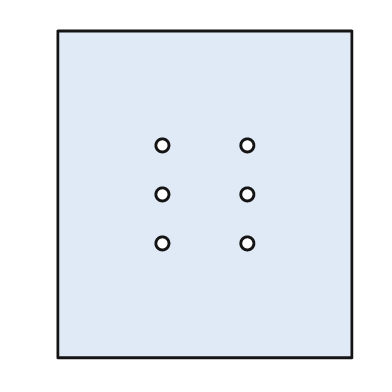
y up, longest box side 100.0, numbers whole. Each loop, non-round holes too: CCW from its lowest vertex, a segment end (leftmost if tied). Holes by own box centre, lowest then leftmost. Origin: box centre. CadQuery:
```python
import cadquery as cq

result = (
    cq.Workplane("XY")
    .moveTo(-45.0, -50.0)
    .lineTo(45.0, -50.0)
    .lineTo(45.0, 50.0)
    .lineTo(-45.0, 50.0)
    .close()
    .moveTo(-13.0, -15.0)
    .circle(2.0)
    .moveTo(13.0, -15.0)
    .circle(2.0)
    .moveTo(-13.0, 0.0)
    .circle(2.0)
    .moveTo(13.0, 0.0)
    .circle(2.0)
    .moveTo(-13.0, 15.0)
    .circle(2.0)
    .moveTo(13.0, 15.0)
    .circle(2.0)
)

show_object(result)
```